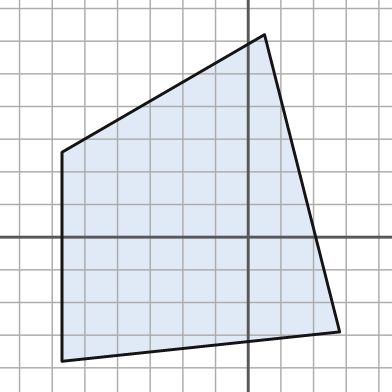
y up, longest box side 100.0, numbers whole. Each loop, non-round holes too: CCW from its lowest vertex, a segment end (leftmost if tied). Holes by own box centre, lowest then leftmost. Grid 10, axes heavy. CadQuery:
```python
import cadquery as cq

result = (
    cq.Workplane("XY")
    .moveTo(-57.0, -38.0)
    .lineTo(28.0, -29.0)
    .lineTo(5.0, 62.0)
    .lineTo(-57.0, 26.0)
    .close()
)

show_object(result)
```